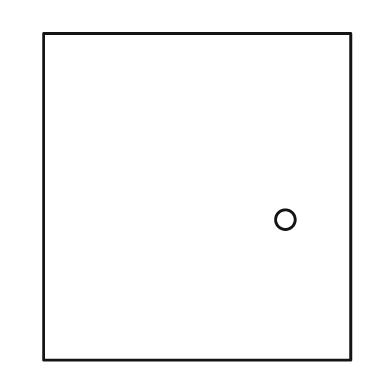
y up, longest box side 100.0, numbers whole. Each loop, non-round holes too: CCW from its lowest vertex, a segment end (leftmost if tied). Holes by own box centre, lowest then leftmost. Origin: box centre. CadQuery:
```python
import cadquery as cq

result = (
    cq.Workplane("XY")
    .moveTo(-47.0, -50.0)
    .lineTo(47.0, -50.0)
    .lineTo(47.0, 50.0)
    .lineTo(-47.0, 50.0)
    .close()
    .moveTo(27.0, -7.0)
    .circle(3.0)
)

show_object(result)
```